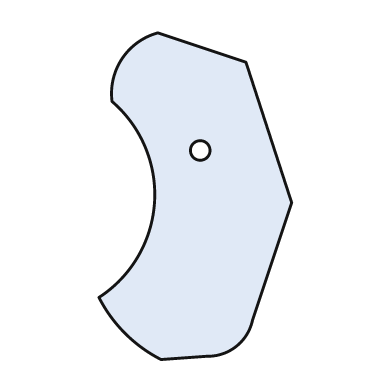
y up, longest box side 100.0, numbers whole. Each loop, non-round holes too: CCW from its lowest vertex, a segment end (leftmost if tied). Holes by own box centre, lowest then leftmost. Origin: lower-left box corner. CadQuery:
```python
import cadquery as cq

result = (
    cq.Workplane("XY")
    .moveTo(19.0, 0.0)
    .lineTo(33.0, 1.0)
    .threePointArc((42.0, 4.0), (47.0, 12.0))
    .lineTo(59.0, 48.0)
    .lineTo(45.0, 91.0)
    .lineTo(18.0, 100.0)
    .threePointArc((7.0, 92.0), (4.0, 79.0))
    .threePointArc((17.0, 48.0), (0.0, 19.0))
    .threePointArc((8.0, 8.0), (19.0, 0.0))
    .close()
    .moveTo(31.0, 64.0)
    .circle(3.0)
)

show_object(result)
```